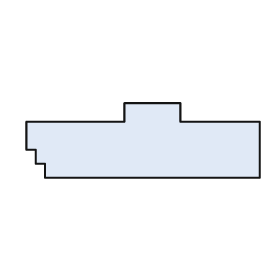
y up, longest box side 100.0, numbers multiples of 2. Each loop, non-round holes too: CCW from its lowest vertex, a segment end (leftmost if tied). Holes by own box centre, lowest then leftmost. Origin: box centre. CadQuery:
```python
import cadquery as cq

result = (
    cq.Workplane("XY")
    .moveTo(-42.0, -16.0)
    .lineTo(50.0, -16.0)
    .lineTo(50.0, 8.0)
    .lineTo(16.0, 8.0)
    .lineTo(16.0, 16.0)
    .lineTo(-8.0, 16.0)
    .lineTo(-8.0, 8.0)
    .lineTo(-50.0, 8.0)
    .lineTo(-50.0, -4.0)
    .lineTo(-46.0, -4.0)
    .lineTo(-46.0, -10.0)
    .lineTo(-42.0, -10.0)
    .close()
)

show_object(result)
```